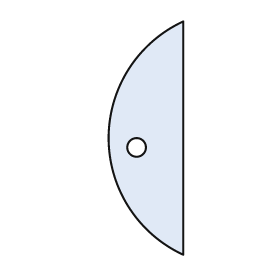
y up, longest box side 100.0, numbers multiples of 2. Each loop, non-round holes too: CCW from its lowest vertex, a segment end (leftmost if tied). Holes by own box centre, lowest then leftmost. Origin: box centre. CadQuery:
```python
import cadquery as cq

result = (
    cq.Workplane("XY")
    .moveTo(16.0, -50.0)
    .lineTo(16.0, 50.0)
    .threePointArc((-16.0, 0.0), (16.0, -50.0))
    .close()
    .moveTo(-4.0, -4.0)
    .circle(4.0)
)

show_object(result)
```